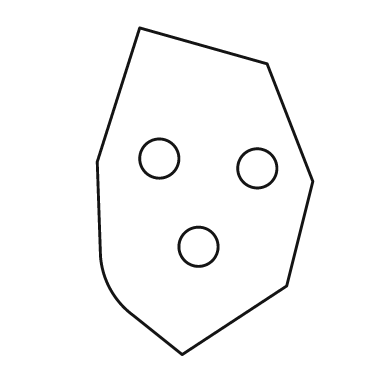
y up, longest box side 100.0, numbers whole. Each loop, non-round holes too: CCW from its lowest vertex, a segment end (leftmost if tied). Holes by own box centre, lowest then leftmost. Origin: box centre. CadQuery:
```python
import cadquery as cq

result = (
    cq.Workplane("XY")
    .moveTo(-7.0, -50.0)
    .lineTo(25.0, -29.0)
    .lineTo(33.0, 3.0)
    .lineTo(19.0, 39.0)
    .lineTo(-20.0, 50.0)
    .lineTo(-33.0, 9.0)
    .lineTo(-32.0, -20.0)
    .threePointArc((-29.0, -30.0), (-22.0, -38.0))
    .close()
    .moveTo(-2.0, -17.0)
    .circle(6.0)
    .moveTo(16.0, 7.0)
    .circle(6.0)
    .moveTo(-14.0, 10.0)
    .circle(6.0)
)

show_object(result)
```